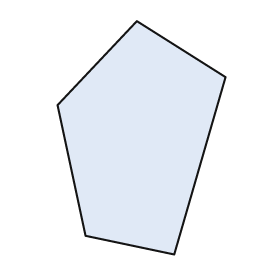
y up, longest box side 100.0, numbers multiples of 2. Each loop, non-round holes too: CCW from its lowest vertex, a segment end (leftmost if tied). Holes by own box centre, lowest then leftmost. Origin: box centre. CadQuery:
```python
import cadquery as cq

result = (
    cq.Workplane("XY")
    .moveTo(14.0, -50.0)
    .lineTo(36.0, 26.0)
    .lineTo(-2.0, 50.0)
    .lineTo(-36.0, 14.0)
    .lineTo(-24.0, -42.0)
    .close()
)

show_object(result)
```